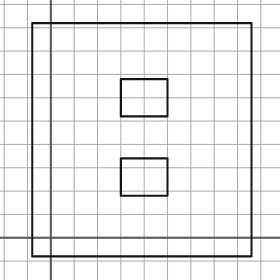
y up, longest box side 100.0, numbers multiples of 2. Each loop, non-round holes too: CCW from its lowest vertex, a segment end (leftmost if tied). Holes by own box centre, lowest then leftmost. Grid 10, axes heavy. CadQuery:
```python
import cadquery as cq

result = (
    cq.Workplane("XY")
    .moveTo(-8.0, -8.0)
    .lineTo(86.0, -8.0)
    .lineTo(86.0, 92.0)
    .lineTo(-8.0, 92.0)
    .close()
    .moveTo(30.0, 18.0)
    .lineTo(50.0, 18.0)
    .lineTo(50.0, 34.0)
    .lineTo(30.0, 34.0)
    .close()
    .moveTo(30.0, 52.0)
    .lineTo(50.0, 52.0)
    .lineTo(50.0, 68.0)
    .lineTo(30.0, 68.0)
    .close()
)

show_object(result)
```